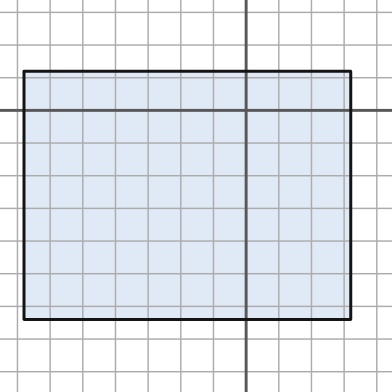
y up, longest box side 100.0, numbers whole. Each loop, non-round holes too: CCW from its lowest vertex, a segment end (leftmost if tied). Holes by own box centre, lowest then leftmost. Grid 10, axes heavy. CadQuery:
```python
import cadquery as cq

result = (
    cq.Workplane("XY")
    .moveTo(-68.0, -64.0)
    .lineTo(32.0, -64.0)
    .lineTo(32.0, 12.0)
    .lineTo(-68.0, 12.0)
    .close()
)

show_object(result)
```